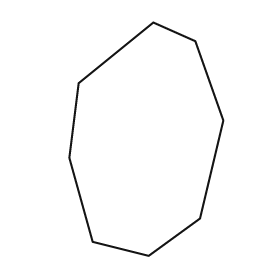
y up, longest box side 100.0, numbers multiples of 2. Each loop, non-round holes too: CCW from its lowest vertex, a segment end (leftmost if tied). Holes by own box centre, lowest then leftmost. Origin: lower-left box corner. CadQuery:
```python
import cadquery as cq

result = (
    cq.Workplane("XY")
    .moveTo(34.0, 0.0)
    .lineTo(56.0, 16.0)
    .lineTo(66.0, 58.0)
    .lineTo(54.0, 92.0)
    .lineTo(36.0, 100.0)
    .lineTo(4.0, 74.0)
    .lineTo(0.0, 42.0)
    .lineTo(10.0, 6.0)
    .close()
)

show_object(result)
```